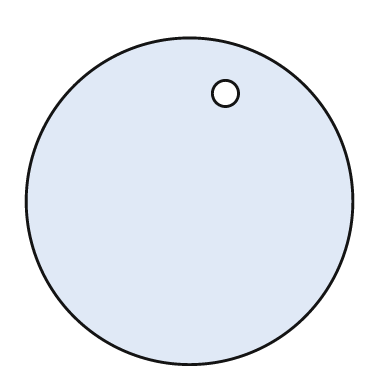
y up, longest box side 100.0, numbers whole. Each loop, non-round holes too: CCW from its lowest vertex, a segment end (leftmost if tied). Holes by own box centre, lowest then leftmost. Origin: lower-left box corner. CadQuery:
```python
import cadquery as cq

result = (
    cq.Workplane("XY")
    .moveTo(50.0, 50.0)
    .circle(50.0)
    .moveTo(61.0, 83.0)
    .circle(4.0)
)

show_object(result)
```